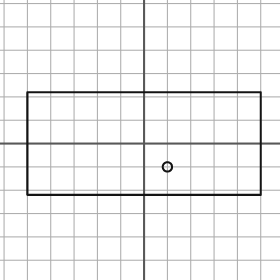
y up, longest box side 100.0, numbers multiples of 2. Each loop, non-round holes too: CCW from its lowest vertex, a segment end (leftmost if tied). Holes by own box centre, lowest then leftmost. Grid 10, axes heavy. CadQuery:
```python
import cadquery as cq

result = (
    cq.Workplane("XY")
    .moveTo(-50.0, -22.0)
    .lineTo(50.0, -22.0)
    .lineTo(50.0, 22.0)
    .lineTo(-50.0, 22.0)
    .close()
    .moveTo(10.0, -10.0)
    .circle(2.0)
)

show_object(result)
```